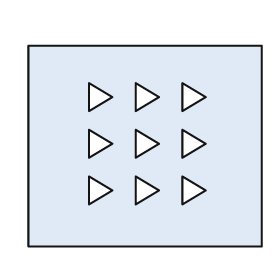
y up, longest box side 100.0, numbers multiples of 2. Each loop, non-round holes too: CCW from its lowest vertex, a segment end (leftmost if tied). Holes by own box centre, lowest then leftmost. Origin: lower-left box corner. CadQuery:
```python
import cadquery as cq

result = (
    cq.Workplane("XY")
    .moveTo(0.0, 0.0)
    .lineTo(100.0, 0.0)
    .lineTo(100.0, 86.0)
    .lineTo(0.0, 86.0)
    .close()
    .moveTo(26.0, 18.0)
    .lineTo(36.0, 24.0)
    .lineTo(26.0, 30.0)
    .close()
    .moveTo(46.0, 18.0)
    .lineTo(56.0, 24.0)
    .lineTo(46.0, 30.0)
    .close()
    .moveTo(66.0, 18.0)
    .lineTo(76.0, 24.0)
    .lineTo(66.0, 30.0)
    .close()
    .moveTo(26.0, 38.0)
    .lineTo(36.0, 44.0)
    .lineTo(26.0, 50.0)
    .close()
    .moveTo(46.0, 38.0)
    .lineTo(56.0, 44.0)
    .lineTo(46.0, 50.0)
    .close()
    .moveTo(66.0, 38.0)
    .lineTo(76.0, 44.0)
    .lineTo(66.0, 50.0)
    .close()
    .moveTo(26.0, 58.0)
    .lineTo(36.0, 64.0)
    .lineTo(26.0, 70.0)
    .close()
    .moveTo(46.0, 58.0)
    .lineTo(56.0, 64.0)
    .lineTo(46.0, 70.0)
    .close()
    .moveTo(66.0, 58.0)
    .lineTo(76.0, 64.0)
    .lineTo(66.0, 70.0)
    .close()
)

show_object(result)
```